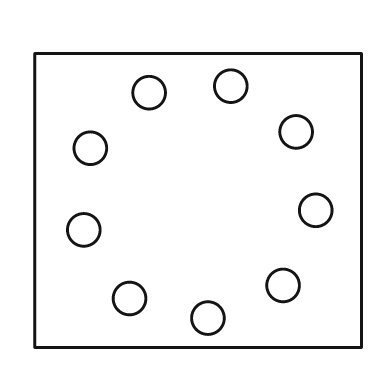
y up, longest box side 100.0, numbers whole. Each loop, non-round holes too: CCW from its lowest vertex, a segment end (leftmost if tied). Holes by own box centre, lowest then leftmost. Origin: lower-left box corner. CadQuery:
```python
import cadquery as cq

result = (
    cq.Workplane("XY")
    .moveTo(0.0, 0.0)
    .lineTo(100.0, 0.0)
    .lineTo(100.0, 90.0)
    .lineTo(0.0, 90.0)
    .close()
    .moveTo(53.0, 9.0)
    .circle(5.0)
    .moveTo(29.0, 15.0)
    .circle(5.0)
    .moveTo(76.0, 19.0)
    .circle(5.0)
    .moveTo(15.0, 36.0)
    .circle(5.0)
    .moveTo(86.0, 42.0)
    .circle(5.0)
    .moveTo(17.0, 61.0)
    .circle(5.0)
    .moveTo(80.0, 66.0)
    .circle(5.0)
    .moveTo(35.0, 78.0)
    .circle(5.0)
    .moveTo(60.0, 80.0)
    .circle(5.0)
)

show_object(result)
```